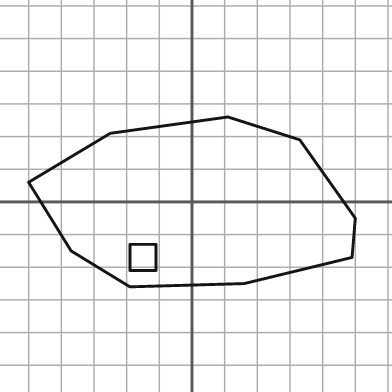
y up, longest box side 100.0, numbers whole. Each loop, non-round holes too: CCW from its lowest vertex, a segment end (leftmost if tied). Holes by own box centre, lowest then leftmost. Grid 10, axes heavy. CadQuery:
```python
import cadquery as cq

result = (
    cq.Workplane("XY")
    .moveTo(-19.0, -26.0)
    .lineTo(16.0, -25.0)
    .lineTo(49.0, -17.0)
    .lineTo(50.0, -5.0)
    .lineTo(33.0, 19.0)
    .lineTo(11.0, 26.0)
    .lineTo(-25.0, 21.0)
    .lineTo(-50.0, 6.0)
    .lineTo(-37.0, -15.0)
    .close()
    .moveTo(-19.0, -21.0)
    .lineTo(-11.0, -21.0)
    .lineTo(-11.0, -13.0)
    .lineTo(-19.0, -13.0)
    .close()
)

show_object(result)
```